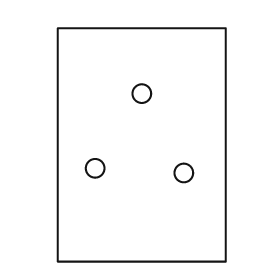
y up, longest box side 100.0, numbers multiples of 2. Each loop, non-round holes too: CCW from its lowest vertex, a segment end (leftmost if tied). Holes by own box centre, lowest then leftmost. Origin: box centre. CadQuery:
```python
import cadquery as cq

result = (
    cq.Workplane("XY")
    .moveTo(-36.0, -50.0)
    .lineTo(36.0, -50.0)
    .lineTo(36.0, 50.0)
    .lineTo(-36.0, 50.0)
    .close()
    .moveTo(18.0, -12.0)
    .circle(4.0)
    .moveTo(-20.0, -10.0)
    .circle(4.0)
    .moveTo(0.0, 22.0)
    .circle(4.0)
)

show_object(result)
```